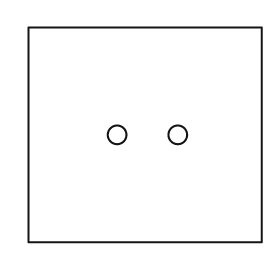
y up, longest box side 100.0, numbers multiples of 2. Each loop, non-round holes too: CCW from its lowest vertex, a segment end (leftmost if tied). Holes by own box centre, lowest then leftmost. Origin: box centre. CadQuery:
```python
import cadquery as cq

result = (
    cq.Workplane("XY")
    .moveTo(-50.0, -46.0)
    .lineTo(50.0, -46.0)
    .lineTo(50.0, 46.0)
    .lineTo(-50.0, 46.0)
    .close()
    .moveTo(-12.0, 0.0)
    .circle(4.0)
    .moveTo(14.0, 0.0)
    .circle(4.0)
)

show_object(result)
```